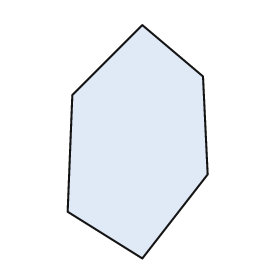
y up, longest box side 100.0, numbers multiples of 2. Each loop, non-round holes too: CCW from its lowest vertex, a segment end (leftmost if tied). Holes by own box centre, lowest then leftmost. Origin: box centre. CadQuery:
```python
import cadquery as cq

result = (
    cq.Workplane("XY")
    .moveTo(2.0, -50.0)
    .lineTo(30.0, -14.0)
    .lineTo(28.0, 28.0)
    .lineTo(2.0, 50.0)
    .lineTo(-28.0, 20.0)
    .lineTo(-30.0, -30.0)
    .close()
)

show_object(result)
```